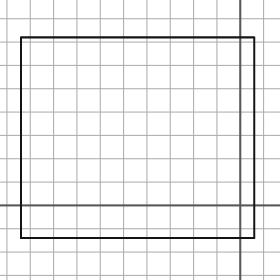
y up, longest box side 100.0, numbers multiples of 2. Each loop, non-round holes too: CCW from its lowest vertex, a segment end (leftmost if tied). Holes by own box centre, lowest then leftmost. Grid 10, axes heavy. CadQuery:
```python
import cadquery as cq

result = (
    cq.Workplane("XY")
    .moveTo(-94.0, -14.0)
    .lineTo(6.0, -14.0)
    .lineTo(6.0, 72.0)
    .lineTo(-94.0, 72.0)
    .close()
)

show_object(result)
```